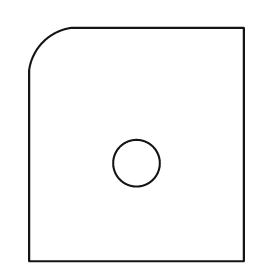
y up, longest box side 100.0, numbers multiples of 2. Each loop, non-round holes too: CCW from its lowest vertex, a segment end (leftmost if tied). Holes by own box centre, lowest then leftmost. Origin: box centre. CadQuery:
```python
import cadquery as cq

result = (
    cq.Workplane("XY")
    .moveTo(-46.0, -50.0)
    .lineTo(46.0, -50.0)
    .lineTo(46.0, 50.0)
    .lineTo(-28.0, 50.0)
    .threePointArc((-40.0, 44.0), (-46.0, 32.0))
    .close()
    .moveTo(0.0, -8.0)
    .circle(10.0)
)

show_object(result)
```